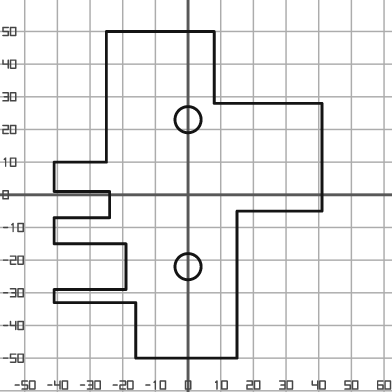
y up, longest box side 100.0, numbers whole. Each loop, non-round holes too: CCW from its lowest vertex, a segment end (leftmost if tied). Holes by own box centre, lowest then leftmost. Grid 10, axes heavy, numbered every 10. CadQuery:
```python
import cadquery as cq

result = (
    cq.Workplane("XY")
    .moveTo(-16.0, -50.0)
    .lineTo(15.0, -50.0)
    .lineTo(15.0, -5.0)
    .lineTo(41.0, -5.0)
    .lineTo(41.0, 28.0)
    .lineTo(8.0, 28.0)
    .lineTo(8.0, 50.0)
    .lineTo(-25.0, 50.0)
    .lineTo(-25.0, 10.0)
    .lineTo(-41.0, 10.0)
    .lineTo(-41.0, 1.0)
    .lineTo(-24.0, 1.0)
    .lineTo(-24.0, -7.0)
    .lineTo(-41.0, -7.0)
    .lineTo(-41.0, -15.0)
    .lineTo(-19.0, -15.0)
    .lineTo(-19.0, -29.0)
    .lineTo(-41.0, -29.0)
    .lineTo(-41.0, -33.0)
    .lineTo(-16.0, -33.0)
    .close()
    .moveTo(0.0, -22.0)
    .circle(4.0)
    .moveTo(0.0, 23.0)
    .circle(4.0)
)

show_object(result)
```